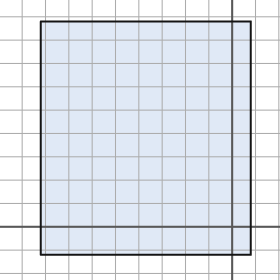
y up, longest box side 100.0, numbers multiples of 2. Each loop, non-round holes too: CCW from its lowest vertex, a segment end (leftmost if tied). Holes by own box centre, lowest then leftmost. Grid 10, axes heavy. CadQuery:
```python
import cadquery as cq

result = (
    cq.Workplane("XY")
    .moveTo(-82.0, -12.0)
    .lineTo(8.0, -12.0)
    .lineTo(8.0, 88.0)
    .lineTo(-82.0, 88.0)
    .close()
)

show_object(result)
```